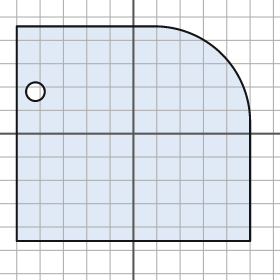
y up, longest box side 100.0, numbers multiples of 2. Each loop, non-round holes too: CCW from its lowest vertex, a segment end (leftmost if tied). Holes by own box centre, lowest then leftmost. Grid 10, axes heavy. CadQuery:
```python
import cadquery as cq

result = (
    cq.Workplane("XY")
    .moveTo(-50.0, -46.0)
    .lineTo(50.0, -46.0)
    .lineTo(50.0, 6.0)
    .threePointArc((38.0, 34.0), (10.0, 46.0))
    .lineTo(-50.0, 46.0)
    .close()
    .moveTo(-42.0, 18.0)
    .circle(4.0)
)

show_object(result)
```